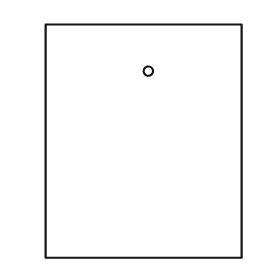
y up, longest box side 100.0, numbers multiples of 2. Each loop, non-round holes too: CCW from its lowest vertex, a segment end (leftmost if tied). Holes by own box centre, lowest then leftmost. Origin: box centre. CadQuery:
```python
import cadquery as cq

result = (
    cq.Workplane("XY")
    .moveTo(-42.0, -50.0)
    .lineTo(42.0, -50.0)
    .lineTo(42.0, 50.0)
    .lineTo(-42.0, 50.0)
    .close()
    .moveTo(2.0, 30.0)
    .circle(2.0)
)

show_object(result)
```